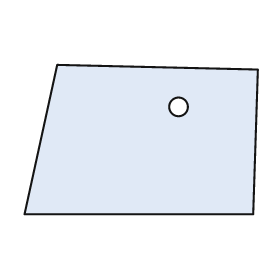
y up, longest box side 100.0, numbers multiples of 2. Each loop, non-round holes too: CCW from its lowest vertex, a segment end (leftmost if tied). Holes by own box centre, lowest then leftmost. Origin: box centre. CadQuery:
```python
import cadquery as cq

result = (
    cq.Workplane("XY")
    .moveTo(-50.0, -32.0)
    .lineTo(48.0, -32.0)
    .lineTo(50.0, 30.0)
    .lineTo(-36.0, 32.0)
    .close()
    .moveTo(16.0, 14.0)
    .circle(4.0)
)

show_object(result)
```